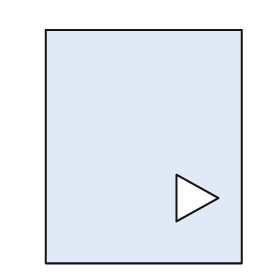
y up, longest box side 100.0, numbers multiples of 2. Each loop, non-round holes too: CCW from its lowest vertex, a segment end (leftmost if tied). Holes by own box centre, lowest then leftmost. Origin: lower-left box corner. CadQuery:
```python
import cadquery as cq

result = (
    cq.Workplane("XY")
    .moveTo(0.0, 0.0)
    .lineTo(84.0, 0.0)
    .lineTo(84.0, 100.0)
    .lineTo(0.0, 100.0)
    .close()
    .moveTo(56.0, 18.0)
    .lineTo(74.0, 28.0)
    .lineTo(56.0, 38.0)
    .close()
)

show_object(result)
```